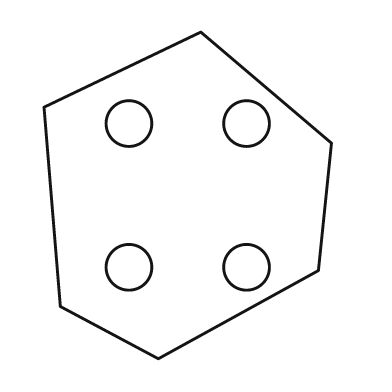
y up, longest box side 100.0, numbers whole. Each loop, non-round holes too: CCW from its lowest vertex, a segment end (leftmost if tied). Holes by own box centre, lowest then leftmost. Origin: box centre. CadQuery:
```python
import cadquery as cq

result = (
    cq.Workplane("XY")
    .moveTo(-9.0, -50.0)
    .lineTo(40.0, -23.0)
    .lineTo(44.0, 16.0)
    .lineTo(4.0, 50.0)
    .lineTo(-44.0, 27.0)
    .lineTo(-39.0, -34.0)
    .close()
    .moveTo(-18.0, -22.0)
    .circle(7.0)
    .moveTo(18.0, -22.0)
    .circle(7.0)
    .moveTo(-18.0, 22.0)
    .circle(7.0)
    .moveTo(18.0, 22.0)
    .circle(7.0)
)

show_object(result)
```